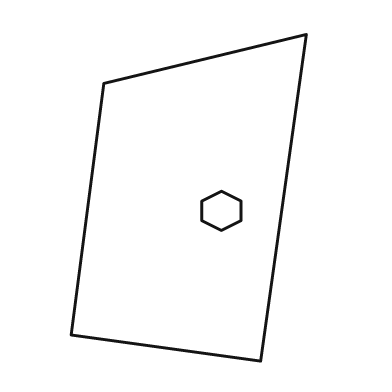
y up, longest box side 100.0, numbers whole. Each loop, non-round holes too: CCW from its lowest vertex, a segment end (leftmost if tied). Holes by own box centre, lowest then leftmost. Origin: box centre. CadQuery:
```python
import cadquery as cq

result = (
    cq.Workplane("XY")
    .moveTo(22.0, -50.0)
    .lineTo(36.0, 50.0)
    .lineTo(-26.0, 35.0)
    .lineTo(-36.0, -42.0)
    .close()
    .moveTo(10.0, -10.0)
    .lineTo(16.0, -7.0)
    .lineTo(16.0, -1.0)
    .lineTo(10.0, 2.0)
    .lineTo(4.0, -1.0)
    .lineTo(4.0, -7.0)
    .close()
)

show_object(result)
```